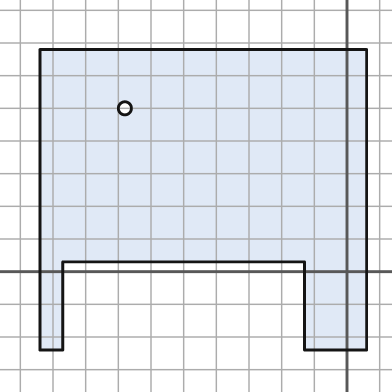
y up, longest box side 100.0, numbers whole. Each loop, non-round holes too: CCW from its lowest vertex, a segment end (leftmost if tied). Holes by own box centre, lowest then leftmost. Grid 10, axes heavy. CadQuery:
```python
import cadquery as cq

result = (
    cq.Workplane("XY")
    .moveTo(-94.0, -24.0)
    .lineTo(-87.0, -24.0)
    .lineTo(-87.0, 3.0)
    .lineTo(-13.0, 3.0)
    .lineTo(-13.0, -24.0)
    .lineTo(6.0, -24.0)
    .lineTo(6.0, 68.0)
    .lineTo(-94.0, 68.0)
    .close()
    .moveTo(-68.0, 50.0)
    .circle(2.0)
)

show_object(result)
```